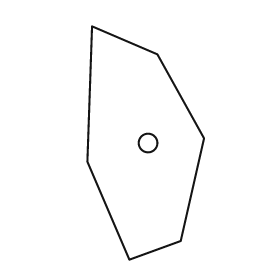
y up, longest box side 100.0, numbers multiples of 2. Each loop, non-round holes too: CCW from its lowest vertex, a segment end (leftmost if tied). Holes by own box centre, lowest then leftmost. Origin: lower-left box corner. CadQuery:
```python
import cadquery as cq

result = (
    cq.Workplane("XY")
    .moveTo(18.0, 0.0)
    .lineTo(40.0, 8.0)
    .lineTo(50.0, 52.0)
    .lineTo(30.0, 88.0)
    .lineTo(2.0, 100.0)
    .lineTo(0.0, 42.0)
    .close()
    .moveTo(26.0, 50.0)
    .circle(4.0)
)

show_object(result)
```